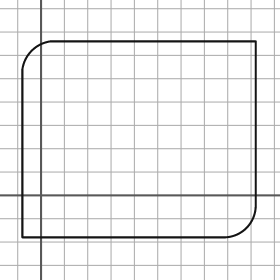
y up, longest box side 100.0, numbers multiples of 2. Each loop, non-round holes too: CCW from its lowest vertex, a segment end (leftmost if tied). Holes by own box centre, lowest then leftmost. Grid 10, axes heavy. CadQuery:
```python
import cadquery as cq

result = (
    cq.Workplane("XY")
    .moveTo(-8.0, -18.0)
    .lineTo(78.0, -18.0)
    .threePointArc((88.0, -14.0), (92.0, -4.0))
    .lineTo(92.0, 66.0)
    .lineTo(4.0, 66.0)
    .threePointArc((-4.0, 62.0), (-8.0, 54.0))
    .close()
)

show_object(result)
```